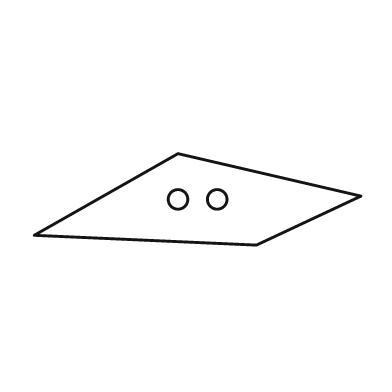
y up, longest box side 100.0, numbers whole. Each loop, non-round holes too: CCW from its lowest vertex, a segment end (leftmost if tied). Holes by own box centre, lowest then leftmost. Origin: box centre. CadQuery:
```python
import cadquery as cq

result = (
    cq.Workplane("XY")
    .moveTo(18.0, -14.0)
    .lineTo(50.0, 1.0)
    .lineTo(-6.0, 14.0)
    .lineTo(-50.0, -11.0)
    .close()
    .moveTo(-6.0, 0.0)
    .circle(3.0)
    .moveTo(6.0, 0.0)
    .circle(3.0)
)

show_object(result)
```